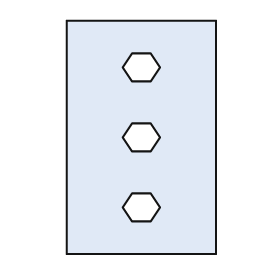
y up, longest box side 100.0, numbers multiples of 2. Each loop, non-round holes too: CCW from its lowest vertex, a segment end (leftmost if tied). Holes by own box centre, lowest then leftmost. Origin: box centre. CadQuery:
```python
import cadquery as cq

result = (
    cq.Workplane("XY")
    .moveTo(-32.0, -50.0)
    .lineTo(32.0, -50.0)
    .lineTo(32.0, 50.0)
    .lineTo(-32.0, 50.0)
    .close()
    .moveTo(-4.0, -36.0)
    .lineTo(4.0, -36.0)
    .lineTo(8.0, -30.0)
    .lineTo(4.0, -24.0)
    .lineTo(-4.0, -24.0)
    .lineTo(-8.0, -30.0)
    .close()
    .moveTo(-4.0, -6.0)
    .lineTo(4.0, -6.0)
    .lineTo(8.0, 0.0)
    .lineTo(4.0, 6.0)
    .lineTo(-4.0, 6.0)
    .lineTo(-8.0, 0.0)
    .close()
    .moveTo(-4.0, 24.0)
    .lineTo(4.0, 24.0)
    .lineTo(8.0, 30.0)
    .lineTo(4.0, 36.0)
    .lineTo(-4.0, 36.0)
    .lineTo(-8.0, 30.0)
    .close()
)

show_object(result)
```